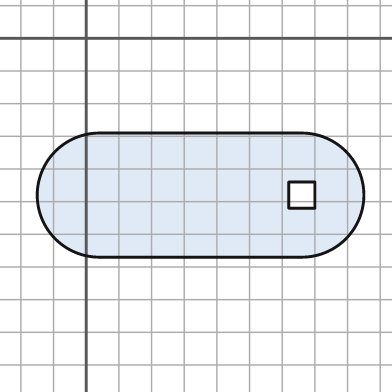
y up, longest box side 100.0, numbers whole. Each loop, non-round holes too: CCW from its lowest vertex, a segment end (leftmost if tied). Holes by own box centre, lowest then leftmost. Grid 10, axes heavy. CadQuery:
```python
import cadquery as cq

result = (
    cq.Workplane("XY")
    .moveTo(4.0, -67.0)
    .lineTo(66.0, -67.0)
    .threePointArc((85.0, -48.0), (66.0, -29.0))
    .lineTo(4.0, -29.0)
    .threePointArc((-15.0, -48.0), (4.0, -67.0))
    .close()
    .moveTo(62.0, -52.0)
    .lineTo(70.0, -52.0)
    .lineTo(70.0, -44.0)
    .lineTo(62.0, -44.0)
    .close()
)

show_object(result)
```